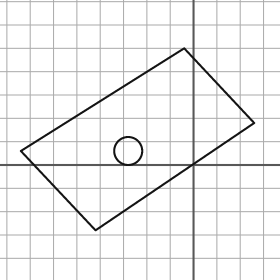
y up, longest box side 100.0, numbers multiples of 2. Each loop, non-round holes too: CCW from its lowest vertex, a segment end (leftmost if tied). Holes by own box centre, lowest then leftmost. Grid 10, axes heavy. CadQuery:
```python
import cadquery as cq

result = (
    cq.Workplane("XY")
    .moveTo(-42.0, -28.0)
    .lineTo(26.0, 18.0)
    .lineTo(-4.0, 50.0)
    .lineTo(-74.0, 6.0)
    .close()
    .moveTo(-28.0, 6.0)
    .circle(6.0)
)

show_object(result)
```